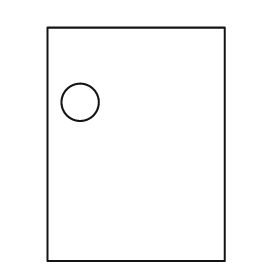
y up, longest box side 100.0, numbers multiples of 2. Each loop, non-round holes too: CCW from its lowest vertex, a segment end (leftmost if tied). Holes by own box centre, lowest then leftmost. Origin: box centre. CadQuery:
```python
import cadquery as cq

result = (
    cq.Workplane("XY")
    .moveTo(-38.0, -50.0)
    .lineTo(38.0, -50.0)
    .lineTo(38.0, 50.0)
    .lineTo(-38.0, 50.0)
    .close()
    .moveTo(-24.0, 18.0)
    .circle(8.0)
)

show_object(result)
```